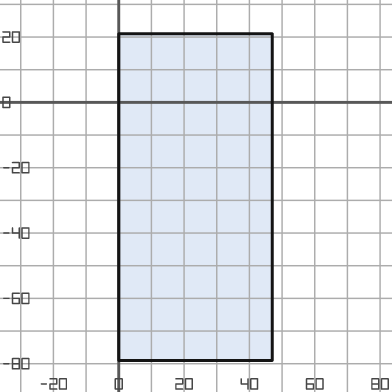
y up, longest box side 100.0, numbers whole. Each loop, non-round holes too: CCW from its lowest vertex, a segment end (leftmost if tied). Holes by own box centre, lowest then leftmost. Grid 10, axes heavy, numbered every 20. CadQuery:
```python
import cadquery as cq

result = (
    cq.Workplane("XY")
    .moveTo(0.0, -79.0)
    .lineTo(47.0, -79.0)
    .lineTo(47.0, 21.0)
    .lineTo(0.0, 21.0)
    .close()
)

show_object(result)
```